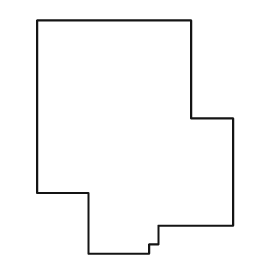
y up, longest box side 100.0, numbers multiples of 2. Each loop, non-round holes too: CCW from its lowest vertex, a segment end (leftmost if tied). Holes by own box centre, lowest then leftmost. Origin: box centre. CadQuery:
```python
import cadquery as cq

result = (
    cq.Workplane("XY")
    .moveTo(-20.0, -50.0)
    .lineTo(6.0, -50.0)
    .lineTo(6.0, -46.0)
    .lineTo(10.0, -46.0)
    .lineTo(10.0, -38.0)
    .lineTo(42.0, -38.0)
    .lineTo(42.0, 8.0)
    .lineTo(24.0, 8.0)
    .lineTo(24.0, 50.0)
    .lineTo(-42.0, 50.0)
    .lineTo(-42.0, -24.0)
    .lineTo(-20.0, -24.0)
    .close()
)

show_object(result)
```